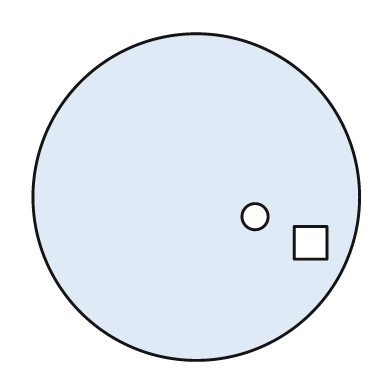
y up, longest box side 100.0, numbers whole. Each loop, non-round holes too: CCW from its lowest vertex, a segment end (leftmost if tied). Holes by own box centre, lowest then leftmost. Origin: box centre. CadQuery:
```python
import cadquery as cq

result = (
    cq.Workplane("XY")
    .moveTo(0.0, 0.0)
    .circle(50.0)
    .moveTo(30.0, -19.0)
    .lineTo(40.0, -19.0)
    .lineTo(40.0, -9.0)
    .lineTo(30.0, -9.0)
    .close()
    .moveTo(18.0, -6.0)
    .circle(4.0)
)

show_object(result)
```